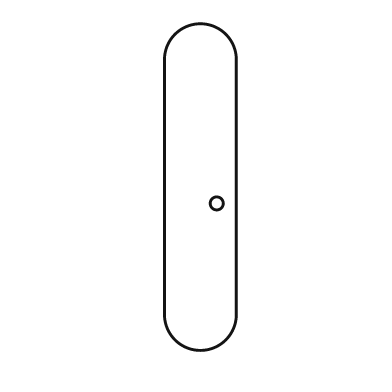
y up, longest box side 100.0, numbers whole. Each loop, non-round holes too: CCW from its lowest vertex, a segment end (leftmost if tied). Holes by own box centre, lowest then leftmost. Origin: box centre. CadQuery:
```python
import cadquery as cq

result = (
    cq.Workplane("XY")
    .moveTo(-11.0, -39.0)
    .threePointArc((0.0, -50.0), (11.0, -39.0))
    .lineTo(11.0, 39.0)
    .threePointArc((0.0, 50.0), (-11.0, 39.0))
    .close()
    .moveTo(5.0, -5.0)
    .circle(2.0)
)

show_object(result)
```